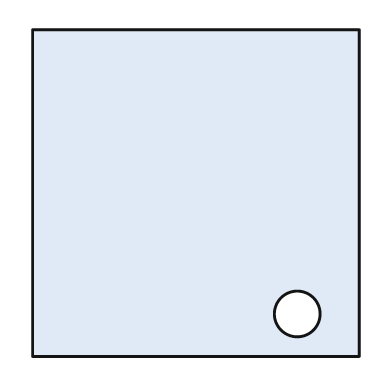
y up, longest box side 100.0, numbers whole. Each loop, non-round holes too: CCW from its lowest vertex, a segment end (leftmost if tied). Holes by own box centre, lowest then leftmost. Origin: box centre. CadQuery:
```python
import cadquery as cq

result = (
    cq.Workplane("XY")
    .moveTo(-50.0, -50.0)
    .lineTo(50.0, -50.0)
    .lineTo(50.0, 50.0)
    .lineTo(-50.0, 50.0)
    .close()
    .moveTo(31.0, -37.0)
    .circle(7.0)
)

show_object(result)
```